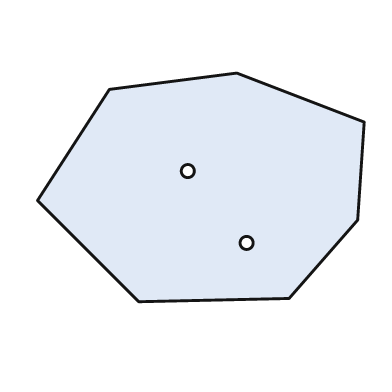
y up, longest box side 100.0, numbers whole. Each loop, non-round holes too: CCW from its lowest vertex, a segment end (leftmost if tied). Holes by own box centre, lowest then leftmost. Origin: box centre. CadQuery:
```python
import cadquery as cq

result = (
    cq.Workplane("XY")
    .moveTo(-19.0, -35.0)
    .lineTo(27.0, -34.0)
    .lineTo(48.0, -10.0)
    .lineTo(50.0, 20.0)
    .lineTo(11.0, 35.0)
    .lineTo(-28.0, 30.0)
    .lineTo(-50.0, -4.0)
    .close()
    .moveTo(14.0, -17.0)
    .circle(2.0)
    .moveTo(-4.0, 5.0)
    .circle(2.0)
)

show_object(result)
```